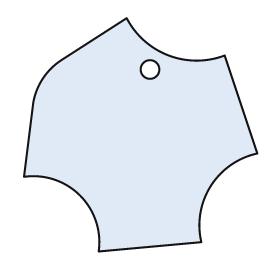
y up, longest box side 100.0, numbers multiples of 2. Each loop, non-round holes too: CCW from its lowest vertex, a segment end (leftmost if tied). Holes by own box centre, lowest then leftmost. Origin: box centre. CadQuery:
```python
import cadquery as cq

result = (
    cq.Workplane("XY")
    .moveTo(-18.0, -50.0)
    .lineTo(26.0, -46.0)
    .threePointArc((30.0, -22.0), (50.0, -8.0))
    .lineTo(36.0, 34.0)
    .threePointArc((12.0, 34.0), (-6.0, 50.0))
    .lineTo(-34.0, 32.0)
    .threePointArc((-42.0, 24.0), (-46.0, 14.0))
    .lineTo(-50.0, -18.0)
    .threePointArc((-26.0, -26.0), (-18.0, -50.0))
    .close()
    .moveTo(4.0, 28.0)
    .circle(4.0)
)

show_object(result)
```